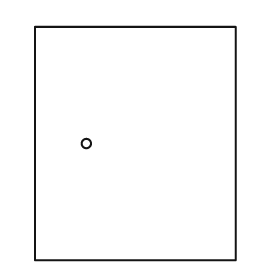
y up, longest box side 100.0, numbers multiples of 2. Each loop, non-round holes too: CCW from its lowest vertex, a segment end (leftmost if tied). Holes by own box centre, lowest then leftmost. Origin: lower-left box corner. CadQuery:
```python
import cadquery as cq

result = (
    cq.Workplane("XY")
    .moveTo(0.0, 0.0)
    .lineTo(86.0, 0.0)
    .lineTo(86.0, 100.0)
    .lineTo(0.0, 100.0)
    .close()
    .moveTo(22.0, 50.0)
    .circle(2.0)
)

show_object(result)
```